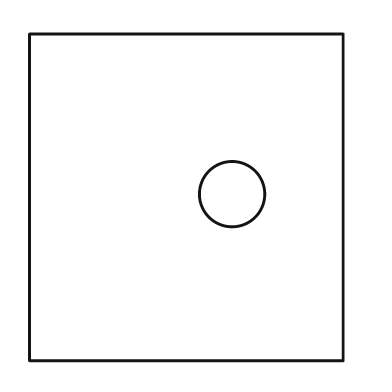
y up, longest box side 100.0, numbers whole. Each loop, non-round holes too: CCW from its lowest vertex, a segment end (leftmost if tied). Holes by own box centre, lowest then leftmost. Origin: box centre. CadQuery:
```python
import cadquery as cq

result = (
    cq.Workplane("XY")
    .moveTo(-48.0, -50.0)
    .lineTo(48.0, -50.0)
    .lineTo(48.0, 50.0)
    .lineTo(-48.0, 50.0)
    .close()
    .moveTo(14.0, 1.0)
    .circle(10.0)
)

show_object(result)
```